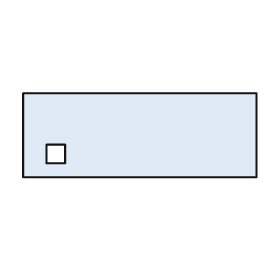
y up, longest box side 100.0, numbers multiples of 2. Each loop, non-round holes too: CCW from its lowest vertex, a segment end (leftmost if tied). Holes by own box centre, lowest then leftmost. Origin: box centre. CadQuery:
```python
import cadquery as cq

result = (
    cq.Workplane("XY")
    .moveTo(-50.0, -18.0)
    .lineTo(50.0, -18.0)
    .lineTo(50.0, 18.0)
    .lineTo(-50.0, 18.0)
    .close()
    .moveTo(-40.0, -12.0)
    .lineTo(-32.0, -12.0)
    .lineTo(-32.0, -4.0)
    .lineTo(-40.0, -4.0)
    .close()
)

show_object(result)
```